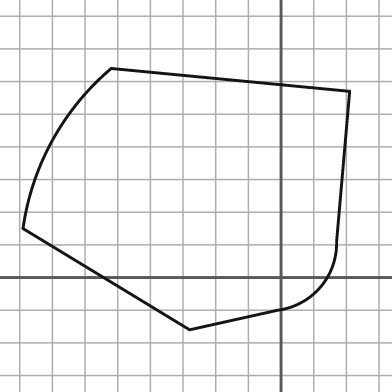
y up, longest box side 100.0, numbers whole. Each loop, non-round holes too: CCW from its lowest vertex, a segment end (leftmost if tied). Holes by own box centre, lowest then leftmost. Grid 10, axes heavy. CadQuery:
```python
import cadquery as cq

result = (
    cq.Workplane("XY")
    .moveTo(-28.0, -16.0)
    .lineTo(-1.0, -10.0)
    .threePointArc((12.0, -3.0), (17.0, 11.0))
    .lineTo(21.0, 57.0)
    .lineTo(-52.0, 64.0)
    .threePointArc((-70.0, 42.0), (-79.0, 15.0))
    .close()
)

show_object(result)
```